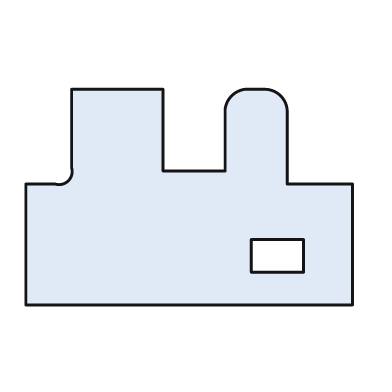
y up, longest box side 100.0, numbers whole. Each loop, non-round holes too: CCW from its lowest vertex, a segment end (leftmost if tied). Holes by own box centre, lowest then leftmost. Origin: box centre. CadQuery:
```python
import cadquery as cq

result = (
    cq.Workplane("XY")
    .moveTo(-50.0, -33.0)
    .lineTo(50.0, -33.0)
    .lineTo(50.0, 4.0)
    .lineTo(30.0, 4.0)
    .lineTo(30.0, 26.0)
    .threePointArc((28.0, 31.0), (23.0, 33.0))
    .lineTo(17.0, 33.0)
    .threePointArc((13.0, 31.0), (11.0, 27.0))
    .lineTo(11.0, 8.0)
    .lineTo(-8.0, 8.0)
    .lineTo(-8.0, 33.0)
    .lineTo(-36.0, 33.0)
    .lineTo(-36.0, 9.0)
    .threePointArc((-37.0, 5.0), (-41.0, 4.0))
    .lineTo(-50.0, 4.0)
    .close()
    .moveTo(19.0, -23.0)
    .lineTo(35.0, -23.0)
    .lineTo(35.0, -13.0)
    .lineTo(19.0, -13.0)
    .close()
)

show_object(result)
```